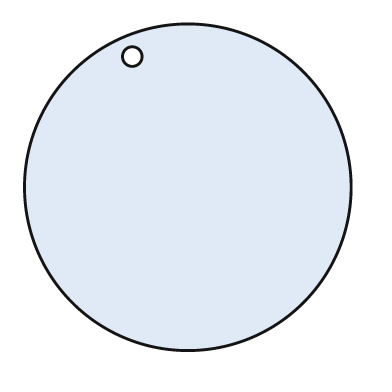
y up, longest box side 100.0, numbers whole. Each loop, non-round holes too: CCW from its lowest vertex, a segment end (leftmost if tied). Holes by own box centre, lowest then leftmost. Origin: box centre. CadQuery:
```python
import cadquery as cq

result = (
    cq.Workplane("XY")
    .moveTo(0.0, 0.0)
    .circle(50.0)
    .moveTo(-17.0, 40.0)
    .circle(3.0)
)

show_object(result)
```